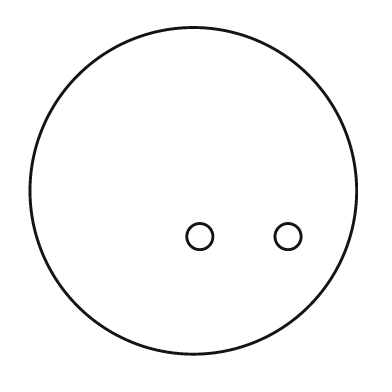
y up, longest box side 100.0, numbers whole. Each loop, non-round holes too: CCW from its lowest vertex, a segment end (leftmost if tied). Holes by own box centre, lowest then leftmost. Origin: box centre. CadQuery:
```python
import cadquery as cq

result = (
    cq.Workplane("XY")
    .moveTo(0.0, 0.0)
    .circle(50.0)
    .moveTo(2.0, -14.0)
    .circle(4.0)
    .moveTo(29.0, -14.0)
    .circle(4.0)
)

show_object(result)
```